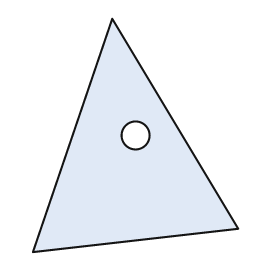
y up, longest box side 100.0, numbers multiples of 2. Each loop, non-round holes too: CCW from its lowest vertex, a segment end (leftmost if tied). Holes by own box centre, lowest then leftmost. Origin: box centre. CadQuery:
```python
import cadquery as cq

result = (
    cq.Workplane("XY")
    .moveTo(-44.0, -50.0)
    .lineTo(44.0, -40.0)
    .lineTo(-10.0, 50.0)
    .close()
    .moveTo(0.0, 0.0)
    .circle(6.0)
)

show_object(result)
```